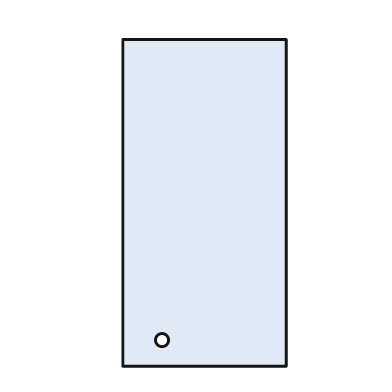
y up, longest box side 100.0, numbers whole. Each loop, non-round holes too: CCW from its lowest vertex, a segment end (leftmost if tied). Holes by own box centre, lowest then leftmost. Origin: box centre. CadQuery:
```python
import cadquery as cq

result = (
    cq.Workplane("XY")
    .moveTo(-25.0, -50.0)
    .lineTo(25.0, -50.0)
    .lineTo(25.0, 50.0)
    .lineTo(-25.0, 50.0)
    .close()
    .moveTo(-13.0, -42.0)
    .circle(2.0)
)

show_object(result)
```